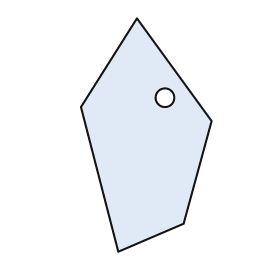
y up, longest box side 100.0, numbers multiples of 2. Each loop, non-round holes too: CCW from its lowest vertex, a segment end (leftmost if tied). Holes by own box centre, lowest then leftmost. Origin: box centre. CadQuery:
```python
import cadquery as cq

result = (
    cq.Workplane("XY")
    .moveTo(-12.0, -50.0)
    .lineTo(16.0, -38.0)
    .lineTo(28.0, 6.0)
    .lineTo(-4.0, 50.0)
    .lineTo(-28.0, 12.0)
    .close()
    .moveTo(8.0, 16.0)
    .circle(4.0)
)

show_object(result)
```